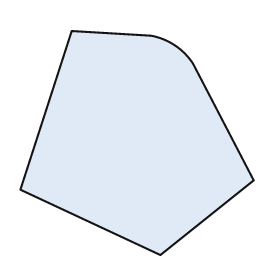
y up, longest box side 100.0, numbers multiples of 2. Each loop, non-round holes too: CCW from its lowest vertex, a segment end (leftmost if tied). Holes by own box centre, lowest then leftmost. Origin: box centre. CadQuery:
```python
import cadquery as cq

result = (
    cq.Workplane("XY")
    .moveTo(10.0, -48.0)
    .lineTo(50.0, -16.0)
    .lineTo(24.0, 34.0)
    .threePointArc((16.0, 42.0), (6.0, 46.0))
    .lineTo(-28.0, 48.0)
    .lineTo(-50.0, -20.0)
    .close()
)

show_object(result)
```